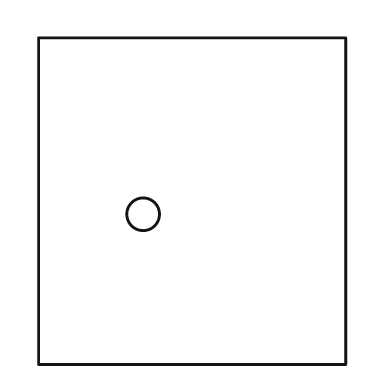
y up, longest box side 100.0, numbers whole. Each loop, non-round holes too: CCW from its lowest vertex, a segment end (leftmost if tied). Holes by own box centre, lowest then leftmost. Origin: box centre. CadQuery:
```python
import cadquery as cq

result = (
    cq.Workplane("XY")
    .moveTo(-47.0, -50.0)
    .lineTo(47.0, -50.0)
    .lineTo(47.0, 50.0)
    .lineTo(-47.0, 50.0)
    .close()
    .moveTo(-15.0, -4.0)
    .circle(5.0)
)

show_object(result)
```